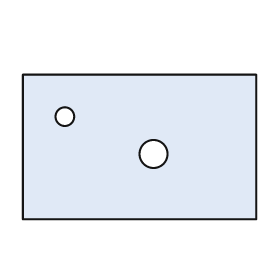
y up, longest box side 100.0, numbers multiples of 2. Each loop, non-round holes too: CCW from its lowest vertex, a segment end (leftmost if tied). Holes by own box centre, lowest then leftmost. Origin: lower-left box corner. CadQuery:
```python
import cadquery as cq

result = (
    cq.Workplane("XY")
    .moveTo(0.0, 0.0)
    .lineTo(100.0, 0.0)
    .lineTo(100.0, 62.0)
    .lineTo(0.0, 62.0)
    .close()
    .moveTo(56.0, 28.0)
    .circle(6.0)
    .moveTo(18.0, 44.0)
    .circle(4.0)
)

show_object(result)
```